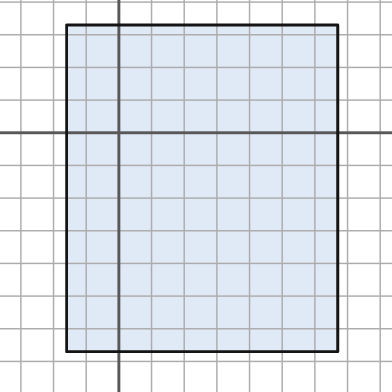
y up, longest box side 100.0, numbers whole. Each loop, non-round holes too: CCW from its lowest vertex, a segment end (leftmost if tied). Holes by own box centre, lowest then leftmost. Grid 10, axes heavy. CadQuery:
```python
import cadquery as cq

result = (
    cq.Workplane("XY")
    .moveTo(-16.0, -67.0)
    .lineTo(67.0, -67.0)
    .lineTo(67.0, 33.0)
    .lineTo(-16.0, 33.0)
    .close()
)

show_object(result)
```